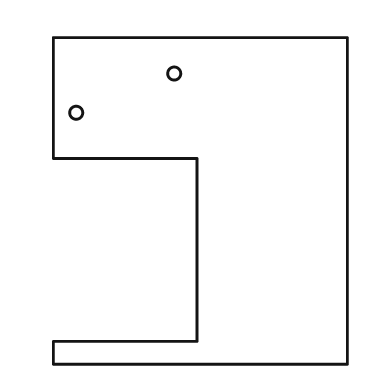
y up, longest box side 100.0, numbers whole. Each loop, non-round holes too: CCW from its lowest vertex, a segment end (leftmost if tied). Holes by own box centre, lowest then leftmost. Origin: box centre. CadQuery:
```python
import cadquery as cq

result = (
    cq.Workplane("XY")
    .moveTo(-45.0, -50.0)
    .lineTo(45.0, -50.0)
    .lineTo(45.0, 50.0)
    .lineTo(-45.0, 50.0)
    .lineTo(-45.0, 13.0)
    .lineTo(-1.0, 13.0)
    .lineTo(-1.0, -43.0)
    .lineTo(-45.0, -43.0)
    .close()
    .moveTo(-38.0, 27.0)
    .circle(2.0)
    .moveTo(-8.0, 39.0)
    .circle(2.0)
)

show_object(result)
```